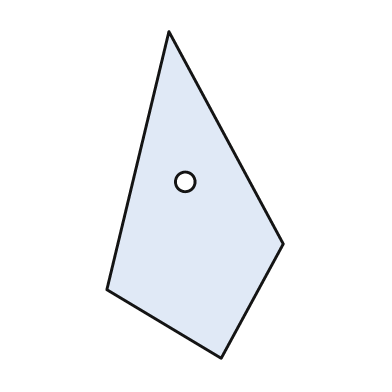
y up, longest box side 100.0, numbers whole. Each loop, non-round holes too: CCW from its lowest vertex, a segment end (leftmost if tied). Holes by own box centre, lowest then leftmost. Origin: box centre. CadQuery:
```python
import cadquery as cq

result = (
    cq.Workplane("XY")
    .moveTo(8.0, -50.0)
    .lineTo(27.0, -15.0)
    .lineTo(-8.0, 50.0)
    .lineTo(-27.0, -29.0)
    .close()
    .moveTo(-3.0, 4.0)
    .circle(3.0)
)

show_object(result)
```